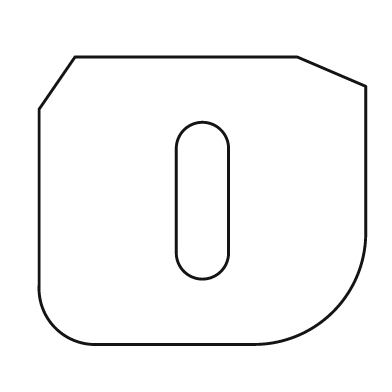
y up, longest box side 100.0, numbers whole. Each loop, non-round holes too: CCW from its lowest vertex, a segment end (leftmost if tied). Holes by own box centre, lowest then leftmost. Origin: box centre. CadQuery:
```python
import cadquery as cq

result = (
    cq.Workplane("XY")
    .moveTo(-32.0, -44.0)
    .lineTo(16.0, -44.0)
    .threePointArc((40.0, -34.0), (50.0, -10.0))
    .lineTo(50.0, 35.0)
    .lineTo(29.0, 44.0)
    .lineTo(-39.0, 44.0)
    .lineTo(-50.0, 28.0)
    .lineTo(-50.0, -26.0)
    .threePointArc((-45.0, -39.0), (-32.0, -44.0))
    .close()
    .moveTo(-8.0, -16.0)
    .threePointArc((0.0, -24.0), (8.0, -16.0))
    .lineTo(8.0, 16.0)
    .threePointArc((0.0, 24.0), (-8.0, 16.0))
    .close()
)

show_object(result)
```